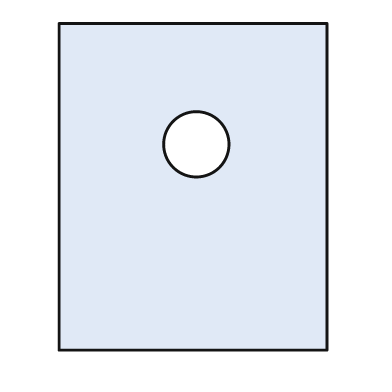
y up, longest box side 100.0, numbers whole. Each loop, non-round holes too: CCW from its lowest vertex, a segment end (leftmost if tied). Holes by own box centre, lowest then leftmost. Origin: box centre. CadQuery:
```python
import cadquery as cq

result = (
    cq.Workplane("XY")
    .moveTo(-41.0, -50.0)
    .lineTo(41.0, -50.0)
    .lineTo(41.0, 50.0)
    .lineTo(-41.0, 50.0)
    .close()
    .moveTo(1.0, 13.0)
    .circle(10.0)
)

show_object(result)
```